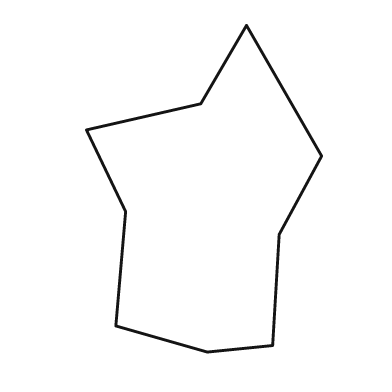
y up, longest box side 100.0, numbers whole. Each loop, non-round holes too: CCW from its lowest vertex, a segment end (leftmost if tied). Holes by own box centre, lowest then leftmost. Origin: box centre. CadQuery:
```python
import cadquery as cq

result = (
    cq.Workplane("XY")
    .moveTo(1.0, -50.0)
    .lineTo(21.0, -48.0)
    .lineTo(23.0, -14.0)
    .lineTo(36.0, 10.0)
    .lineTo(13.0, 50.0)
    .lineTo(-1.0, 26.0)
    .lineTo(-36.0, 18.0)
    .lineTo(-24.0, -7.0)
    .lineTo(-27.0, -42.0)
    .close()
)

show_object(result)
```